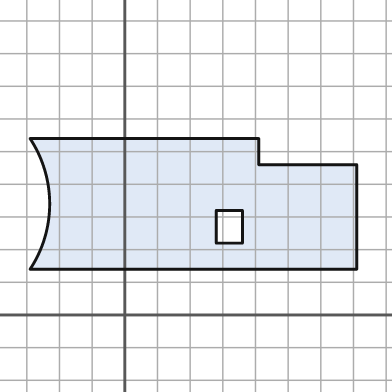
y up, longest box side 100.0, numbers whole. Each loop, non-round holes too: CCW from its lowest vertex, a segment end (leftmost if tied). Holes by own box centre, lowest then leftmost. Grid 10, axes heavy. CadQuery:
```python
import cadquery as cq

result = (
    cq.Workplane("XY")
    .moveTo(-29.0, 14.0)
    .lineTo(71.0, 14.0)
    .lineTo(71.0, 46.0)
    .lineTo(41.0, 46.0)
    .lineTo(41.0, 54.0)
    .lineTo(-29.0, 54.0)
    .threePointArc((-23.0, 34.0), (-29.0, 14.0))
    .close()
    .moveTo(28.0, 22.0)
    .lineTo(36.0, 22.0)
    .lineTo(36.0, 32.0)
    .lineTo(28.0, 32.0)
    .close()
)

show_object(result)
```